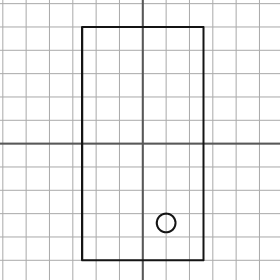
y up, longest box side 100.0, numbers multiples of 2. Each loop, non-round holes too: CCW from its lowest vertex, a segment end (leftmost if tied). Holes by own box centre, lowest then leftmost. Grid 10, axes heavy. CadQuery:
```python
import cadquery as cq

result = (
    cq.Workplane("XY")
    .moveTo(-26.0, -50.0)
    .lineTo(26.0, -50.0)
    .lineTo(26.0, 50.0)
    .lineTo(-26.0, 50.0)
    .close()
    .moveTo(10.0, -34.0)
    .circle(4.0)
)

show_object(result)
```